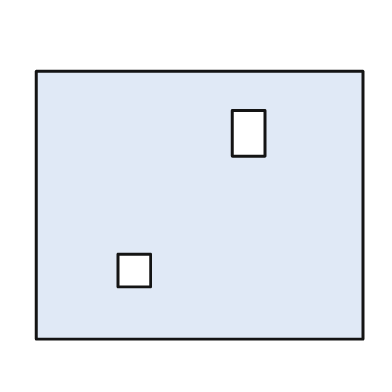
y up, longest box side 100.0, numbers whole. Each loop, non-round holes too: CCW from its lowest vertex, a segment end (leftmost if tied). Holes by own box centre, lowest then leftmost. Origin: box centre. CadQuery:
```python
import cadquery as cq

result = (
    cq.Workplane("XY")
    .moveTo(-50.0, -41.0)
    .lineTo(50.0, -41.0)
    .lineTo(50.0, 41.0)
    .lineTo(-50.0, 41.0)
    .close()
    .moveTo(-25.0, -25.0)
    .lineTo(-15.0, -25.0)
    .lineTo(-15.0, -15.0)
    .lineTo(-25.0, -15.0)
    .close()
    .moveTo(10.0, 15.0)
    .lineTo(20.0, 15.0)
    .lineTo(20.0, 29.0)
    .lineTo(10.0, 29.0)
    .close()
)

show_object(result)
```